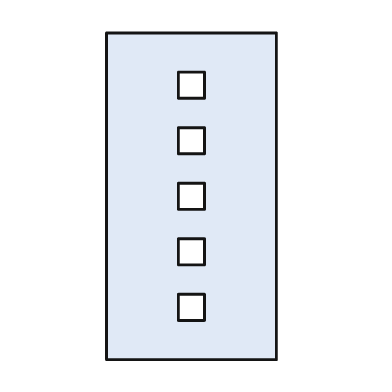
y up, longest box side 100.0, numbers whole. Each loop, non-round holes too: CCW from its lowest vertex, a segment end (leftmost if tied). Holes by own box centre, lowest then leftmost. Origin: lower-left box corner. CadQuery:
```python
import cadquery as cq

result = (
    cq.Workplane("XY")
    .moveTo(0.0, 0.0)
    .lineTo(52.0, 0.0)
    .lineTo(52.0, 100.0)
    .lineTo(0.0, 100.0)
    .close()
    .moveTo(22.0, 12.0)
    .lineTo(30.0, 12.0)
    .lineTo(30.0, 20.0)
    .lineTo(22.0, 20.0)
    .close()
    .moveTo(22.0, 29.0)
    .lineTo(30.0, 29.0)
    .lineTo(30.0, 37.0)
    .lineTo(22.0, 37.0)
    .close()
    .moveTo(22.0, 46.0)
    .lineTo(30.0, 46.0)
    .lineTo(30.0, 54.0)
    .lineTo(22.0, 54.0)
    .close()
    .moveTo(22.0, 63.0)
    .lineTo(30.0, 63.0)
    .lineTo(30.0, 71.0)
    .lineTo(22.0, 71.0)
    .close()
    .moveTo(22.0, 80.0)
    .lineTo(30.0, 80.0)
    .lineTo(30.0, 88.0)
    .lineTo(22.0, 88.0)
    .close()
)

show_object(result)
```